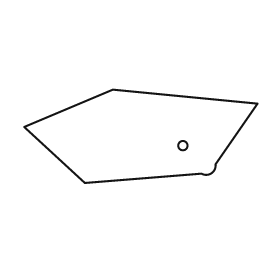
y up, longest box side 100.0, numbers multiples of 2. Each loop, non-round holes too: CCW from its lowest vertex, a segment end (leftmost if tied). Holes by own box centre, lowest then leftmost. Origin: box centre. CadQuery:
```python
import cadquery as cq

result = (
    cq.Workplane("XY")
    .moveTo(-24.0, -20.0)
    .lineTo(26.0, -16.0)
    .threePointArc((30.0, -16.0), (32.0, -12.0))
    .lineTo(50.0, 14.0)
    .lineTo(-12.0, 20.0)
    .lineTo(-50.0, 4.0)
    .close()
    .moveTo(18.0, -4.0)
    .circle(2.0)
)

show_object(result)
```